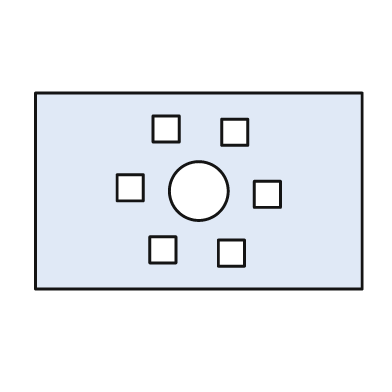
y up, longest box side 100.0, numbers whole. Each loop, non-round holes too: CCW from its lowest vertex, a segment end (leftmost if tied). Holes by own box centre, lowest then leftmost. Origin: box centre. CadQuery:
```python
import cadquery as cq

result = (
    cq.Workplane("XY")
    .moveTo(-50.0, -30.0)
    .lineTo(50.0, -30.0)
    .lineTo(50.0, 30.0)
    .lineTo(-50.0, 30.0)
    .close()
    .moveTo(6.0, -23.0)
    .lineTo(14.0, -23.0)
    .lineTo(14.0, -15.0)
    .lineTo(6.0, -15.0)
    .close()
    .moveTo(-15.0, -22.0)
    .lineTo(-7.0, -22.0)
    .lineTo(-7.0, -14.0)
    .lineTo(-15.0, -14.0)
    .close()
    .moveTo(17.0, -5.0)
    .lineTo(25.0, -5.0)
    .lineTo(25.0, 3.0)
    .lineTo(17.0, 3.0)
    .close()
    .moveTo(0.0, 0.0)
    .circle(9.0)
    .moveTo(-25.0, -3.0)
    .lineTo(-17.0, -3.0)
    .lineTo(-17.0, 5.0)
    .lineTo(-25.0, 5.0)
    .close()
    .moveTo(7.0, 14.0)
    .lineTo(15.0, 14.0)
    .lineTo(15.0, 22.0)
    .lineTo(7.0, 22.0)
    .close()
    .moveTo(-14.0, 15.0)
    .lineTo(-6.0, 15.0)
    .lineTo(-6.0, 23.0)
    .lineTo(-14.0, 23.0)
    .close()
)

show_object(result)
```